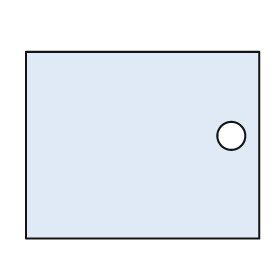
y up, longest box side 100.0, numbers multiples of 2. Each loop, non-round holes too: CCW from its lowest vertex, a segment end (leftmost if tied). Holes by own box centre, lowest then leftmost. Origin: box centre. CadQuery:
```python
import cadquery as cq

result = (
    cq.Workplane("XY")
    .moveTo(-50.0, -40.0)
    .lineTo(50.0, -40.0)
    .lineTo(50.0, 40.0)
    .lineTo(-50.0, 40.0)
    .close()
    .moveTo(38.0, 4.0)
    .circle(6.0)
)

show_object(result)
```